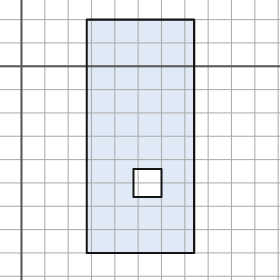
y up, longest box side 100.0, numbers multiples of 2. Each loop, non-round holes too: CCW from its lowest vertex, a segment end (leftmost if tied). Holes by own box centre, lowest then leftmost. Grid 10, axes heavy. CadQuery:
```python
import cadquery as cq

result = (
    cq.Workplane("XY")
    .moveTo(28.0, -80.0)
    .lineTo(74.0, -80.0)
    .lineTo(74.0, 20.0)
    .lineTo(28.0, 20.0)
    .close()
    .moveTo(48.0, -56.0)
    .lineTo(60.0, -56.0)
    .lineTo(60.0, -44.0)
    .lineTo(48.0, -44.0)
    .close()
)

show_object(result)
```